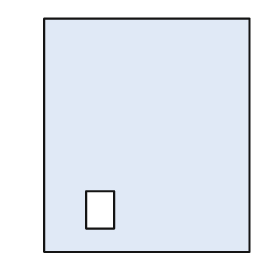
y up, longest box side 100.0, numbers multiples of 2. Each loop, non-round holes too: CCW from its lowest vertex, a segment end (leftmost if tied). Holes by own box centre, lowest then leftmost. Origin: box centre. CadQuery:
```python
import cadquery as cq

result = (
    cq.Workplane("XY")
    .moveTo(-44.0, -50.0)
    .lineTo(44.0, -50.0)
    .lineTo(44.0, 50.0)
    .lineTo(-44.0, 50.0)
    .close()
    .moveTo(-26.0, -40.0)
    .lineTo(-14.0, -40.0)
    .lineTo(-14.0, -24.0)
    .lineTo(-26.0, -24.0)
    .close()
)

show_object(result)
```